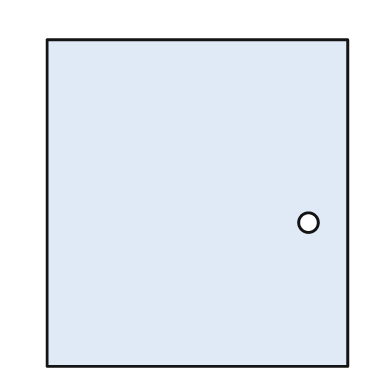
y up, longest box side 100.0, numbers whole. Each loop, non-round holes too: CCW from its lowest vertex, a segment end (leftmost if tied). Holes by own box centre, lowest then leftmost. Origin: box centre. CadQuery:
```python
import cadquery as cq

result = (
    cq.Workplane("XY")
    .moveTo(-46.0, -50.0)
    .lineTo(46.0, -50.0)
    .lineTo(46.0, 50.0)
    .lineTo(-46.0, 50.0)
    .close()
    .moveTo(34.0, -6.0)
    .circle(3.0)
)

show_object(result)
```